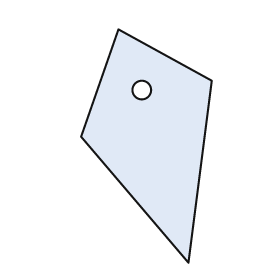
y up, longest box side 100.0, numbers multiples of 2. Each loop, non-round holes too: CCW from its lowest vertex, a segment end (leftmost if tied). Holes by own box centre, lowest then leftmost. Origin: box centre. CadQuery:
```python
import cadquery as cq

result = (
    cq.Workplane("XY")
    .moveTo(18.0, -50.0)
    .lineTo(28.0, 28.0)
    .lineTo(-12.0, 50.0)
    .lineTo(-28.0, 4.0)
    .close()
    .moveTo(-2.0, 24.0)
    .circle(4.0)
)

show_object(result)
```